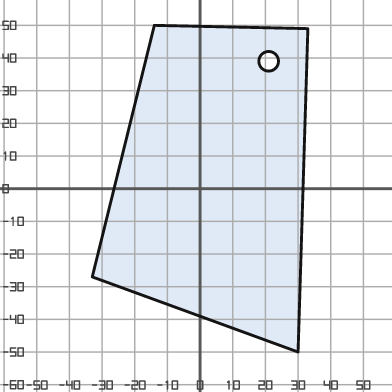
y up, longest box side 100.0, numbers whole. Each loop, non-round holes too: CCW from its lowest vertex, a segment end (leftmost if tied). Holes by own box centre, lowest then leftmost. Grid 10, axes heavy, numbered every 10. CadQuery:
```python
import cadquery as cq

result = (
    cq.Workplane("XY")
    .moveTo(30.0, -50.0)
    .lineTo(33.0, 49.0)
    .lineTo(-14.0, 50.0)
    .lineTo(-33.0, -27.0)
    .close()
    .moveTo(21.0, 39.0)
    .circle(3.0)
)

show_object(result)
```